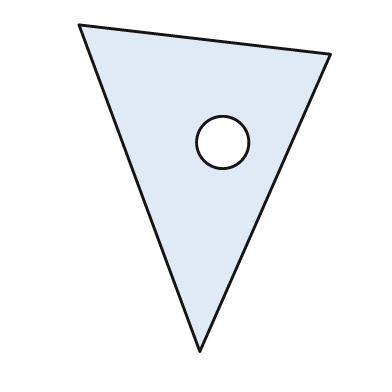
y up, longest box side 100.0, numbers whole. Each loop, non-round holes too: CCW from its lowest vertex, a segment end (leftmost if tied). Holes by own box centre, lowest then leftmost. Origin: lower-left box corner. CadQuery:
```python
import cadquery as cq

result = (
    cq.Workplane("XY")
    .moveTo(37.0, 0.0)
    .lineTo(77.0, 91.0)
    .lineTo(0.0, 100.0)
    .close()
    .moveTo(44.0, 64.0)
    .circle(8.0)
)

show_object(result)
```